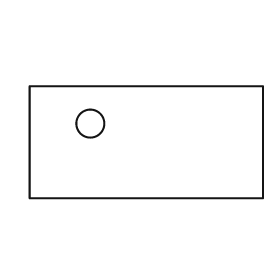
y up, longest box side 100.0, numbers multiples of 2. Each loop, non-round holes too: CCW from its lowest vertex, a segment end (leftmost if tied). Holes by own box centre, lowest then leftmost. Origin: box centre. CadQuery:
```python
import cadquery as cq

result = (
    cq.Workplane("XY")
    .moveTo(-50.0, -24.0)
    .lineTo(50.0, -24.0)
    .lineTo(50.0, 24.0)
    .lineTo(-50.0, 24.0)
    .close()
    .moveTo(-24.0, 8.0)
    .circle(6.0)
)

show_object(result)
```